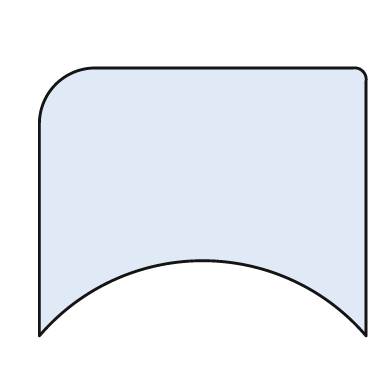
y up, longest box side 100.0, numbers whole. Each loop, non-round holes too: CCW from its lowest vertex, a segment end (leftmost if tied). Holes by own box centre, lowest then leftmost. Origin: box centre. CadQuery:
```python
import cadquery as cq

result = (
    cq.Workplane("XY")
    .moveTo(-50.0, -41.0)
    .threePointArc((0.0, -18.0), (50.0, -41.0))
    .lineTo(50.0, 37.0)
    .threePointArc((49.0, 40.0), (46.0, 41.0))
    .lineTo(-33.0, 41.0)
    .threePointArc((-45.0, 36.0), (-50.0, 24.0))
    .close()
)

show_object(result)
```